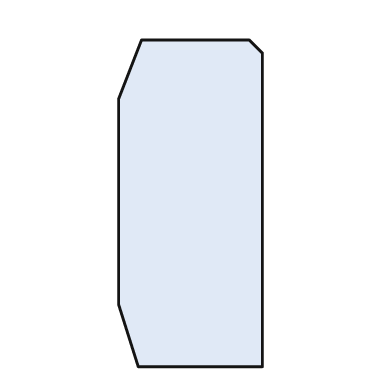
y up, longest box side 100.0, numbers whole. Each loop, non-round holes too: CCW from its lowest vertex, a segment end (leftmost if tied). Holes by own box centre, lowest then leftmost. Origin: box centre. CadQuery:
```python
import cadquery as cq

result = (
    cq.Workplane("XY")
    .moveTo(-16.0, -50.0)
    .lineTo(22.0, -50.0)
    .lineTo(22.0, 46.0)
    .lineTo(18.0, 50.0)
    .lineTo(-15.0, 50.0)
    .lineTo(-22.0, 32.0)
    .lineTo(-22.0, -31.0)
    .close()
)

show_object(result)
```